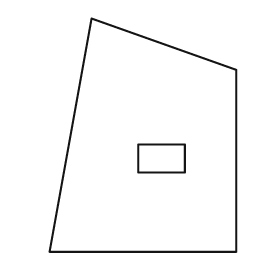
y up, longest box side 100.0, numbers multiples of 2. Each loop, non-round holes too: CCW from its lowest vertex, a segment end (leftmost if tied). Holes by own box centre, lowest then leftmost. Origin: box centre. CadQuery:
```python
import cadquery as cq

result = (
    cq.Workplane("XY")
    .moveTo(-40.0, -50.0)
    .lineTo(40.0, -50.0)
    .lineTo(40.0, 28.0)
    .lineTo(-22.0, 50.0)
    .close()
    .moveTo(-2.0, -16.0)
    .lineTo(18.0, -16.0)
    .lineTo(18.0, -4.0)
    .lineTo(-2.0, -4.0)
    .close()
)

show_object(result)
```